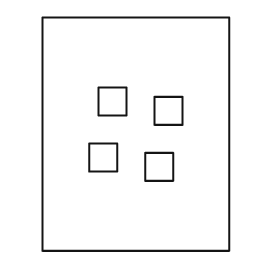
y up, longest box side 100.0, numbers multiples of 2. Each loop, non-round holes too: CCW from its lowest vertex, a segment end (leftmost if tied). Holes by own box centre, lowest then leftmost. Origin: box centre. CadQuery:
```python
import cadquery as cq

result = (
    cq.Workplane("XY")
    .moveTo(-40.0, -50.0)
    .lineTo(40.0, -50.0)
    .lineTo(40.0, 50.0)
    .lineTo(-40.0, 50.0)
    .close()
    .moveTo(4.0, -20.0)
    .lineTo(16.0, -20.0)
    .lineTo(16.0, -8.0)
    .lineTo(4.0, -8.0)
    .close()
    .moveTo(-20.0, -16.0)
    .lineTo(-8.0, -16.0)
    .lineTo(-8.0, -4.0)
    .lineTo(-20.0, -4.0)
    .close()
    .moveTo(8.0, 4.0)
    .lineTo(20.0, 4.0)
    .lineTo(20.0, 16.0)
    .lineTo(8.0, 16.0)
    .close()
    .moveTo(-16.0, 8.0)
    .lineTo(-4.0, 8.0)
    .lineTo(-4.0, 20.0)
    .lineTo(-16.0, 20.0)
    .close()
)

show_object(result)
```